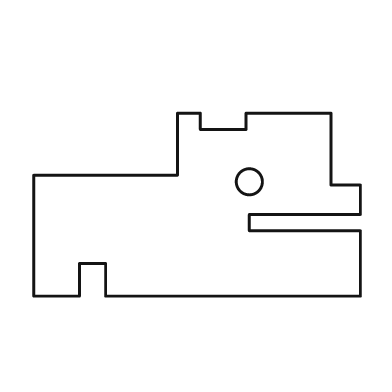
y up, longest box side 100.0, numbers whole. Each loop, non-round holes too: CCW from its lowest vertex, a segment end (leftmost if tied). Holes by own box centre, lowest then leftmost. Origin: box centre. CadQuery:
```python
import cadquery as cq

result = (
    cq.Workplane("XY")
    .moveTo(-50.0, -28.0)
    .lineTo(-36.0, -28.0)
    .lineTo(-36.0, -18.0)
    .lineTo(-28.0, -18.0)
    .lineTo(-28.0, -28.0)
    .lineTo(50.0, -28.0)
    .lineTo(50.0, -8.0)
    .lineTo(16.0, -8.0)
    .lineTo(16.0, -3.0)
    .lineTo(50.0, -3.0)
    .lineTo(50.0, 6.0)
    .lineTo(41.0, 6.0)
    .lineTo(41.0, 28.0)
    .lineTo(15.0, 28.0)
    .lineTo(15.0, 23.0)
    .lineTo(1.0, 23.0)
    .lineTo(1.0, 28.0)
    .lineTo(-6.0, 28.0)
    .lineTo(-6.0, 9.0)
    .lineTo(-50.0, 9.0)
    .close()
    .moveTo(16.0, 7.0)
    .circle(4.0)
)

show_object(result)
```